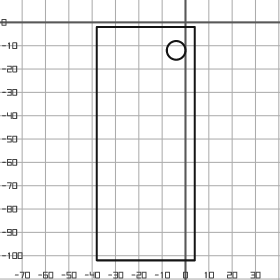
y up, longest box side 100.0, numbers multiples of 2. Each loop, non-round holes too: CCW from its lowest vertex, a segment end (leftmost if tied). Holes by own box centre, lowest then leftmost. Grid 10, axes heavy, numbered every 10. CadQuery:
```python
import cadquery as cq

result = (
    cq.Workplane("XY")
    .moveTo(-38.0, -102.0)
    .lineTo(4.0, -102.0)
    .lineTo(4.0, -2.0)
    .lineTo(-38.0, -2.0)
    .close()
    .moveTo(-4.0, -12.0)
    .circle(4.0)
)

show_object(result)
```